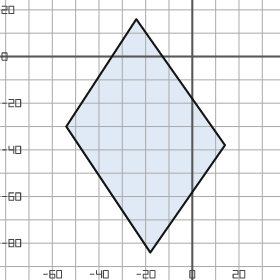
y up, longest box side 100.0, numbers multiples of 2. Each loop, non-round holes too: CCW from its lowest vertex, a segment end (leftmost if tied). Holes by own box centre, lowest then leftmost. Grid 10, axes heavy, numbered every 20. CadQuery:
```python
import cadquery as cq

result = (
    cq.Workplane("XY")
    .moveTo(-18.0, -84.0)
    .lineTo(14.0, -38.0)
    .lineTo(-24.0, 16.0)
    .lineTo(-54.0, -30.0)
    .close()
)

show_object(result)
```